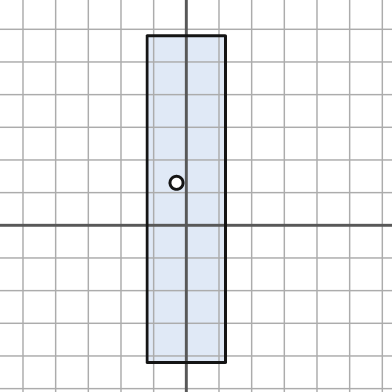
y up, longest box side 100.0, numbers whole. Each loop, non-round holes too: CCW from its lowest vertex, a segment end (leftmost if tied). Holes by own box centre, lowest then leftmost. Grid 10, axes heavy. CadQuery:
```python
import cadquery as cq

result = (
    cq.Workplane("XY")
    .moveTo(-12.0, -42.0)
    .lineTo(12.0, -42.0)
    .lineTo(12.0, 58.0)
    .lineTo(-12.0, 58.0)
    .close()
    .moveTo(-3.0, 13.0)
    .circle(2.0)
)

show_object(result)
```